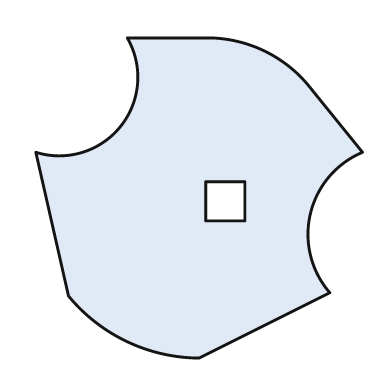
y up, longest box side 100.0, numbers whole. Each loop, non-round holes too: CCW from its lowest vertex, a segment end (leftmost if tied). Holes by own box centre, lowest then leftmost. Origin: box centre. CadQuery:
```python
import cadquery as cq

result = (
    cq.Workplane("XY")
    .moveTo(0.0, -49.0)
    .lineTo(40.0, -29.0)
    .threePointArc((34.0, -5.0), (50.0, 14.0))
    .lineTo(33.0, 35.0)
    .threePointArc((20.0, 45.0), (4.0, 49.0))
    .lineTo(-22.0, 49.0)
    .threePointArc((-24.0, 22.0), (-50.0, 14.0))
    .lineTo(-40.0, -30.0)
    .threePointArc((-22.0, -44.0), (0.0, -49.0))
    .close()
    .moveTo(2.0, -7.0)
    .lineTo(14.0, -7.0)
    .lineTo(14.0, 5.0)
    .lineTo(2.0, 5.0)
    .close()
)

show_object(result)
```